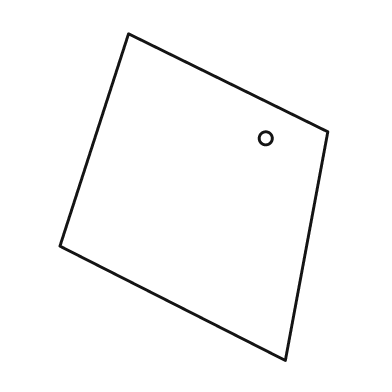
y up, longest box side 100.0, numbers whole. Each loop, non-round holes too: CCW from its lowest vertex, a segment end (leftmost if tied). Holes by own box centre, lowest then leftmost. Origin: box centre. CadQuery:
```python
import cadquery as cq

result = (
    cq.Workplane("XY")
    .moveTo(28.0, -50.0)
    .lineTo(41.0, 20.0)
    .lineTo(-20.0, 50.0)
    .lineTo(-41.0, -15.0)
    .close()
    .moveTo(22.0, 18.0)
    .circle(2.0)
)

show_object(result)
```